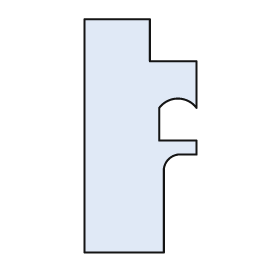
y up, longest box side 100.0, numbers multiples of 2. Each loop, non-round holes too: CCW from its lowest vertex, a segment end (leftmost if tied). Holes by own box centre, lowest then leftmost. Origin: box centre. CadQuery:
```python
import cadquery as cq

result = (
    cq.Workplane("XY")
    .moveTo(-24.0, -50.0)
    .lineTo(10.0, -50.0)
    .lineTo(10.0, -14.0)
    .threePointArc((12.0, -10.0), (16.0, -8.0))
    .lineTo(24.0, -8.0)
    .lineTo(24.0, -2.0)
    .lineTo(8.0, -2.0)
    .lineTo(8.0, 12.0)
    .threePointArc((16.0, 16.0), (24.0, 12.0))
    .lineTo(24.0, 32.0)
    .lineTo(4.0, 32.0)
    .lineTo(4.0, 50.0)
    .lineTo(-24.0, 50.0)
    .close()
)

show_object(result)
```